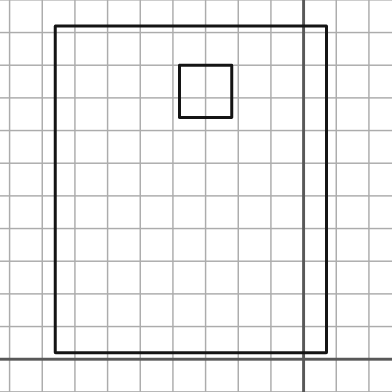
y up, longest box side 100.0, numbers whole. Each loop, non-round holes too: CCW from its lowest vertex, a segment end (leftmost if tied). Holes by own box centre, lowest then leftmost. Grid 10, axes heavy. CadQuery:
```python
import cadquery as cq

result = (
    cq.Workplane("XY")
    .moveTo(-76.0, 2.0)
    .lineTo(7.0, 2.0)
    .lineTo(7.0, 102.0)
    .lineTo(-76.0, 102.0)
    .close()
    .moveTo(-38.0, 74.0)
    .lineTo(-22.0, 74.0)
    .lineTo(-22.0, 90.0)
    .lineTo(-38.0, 90.0)
    .close()
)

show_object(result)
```